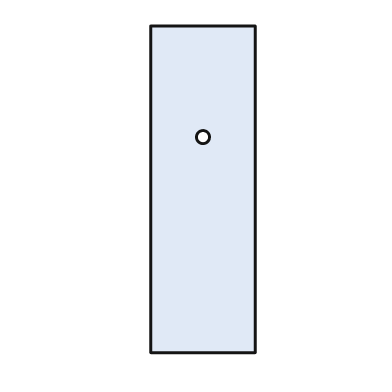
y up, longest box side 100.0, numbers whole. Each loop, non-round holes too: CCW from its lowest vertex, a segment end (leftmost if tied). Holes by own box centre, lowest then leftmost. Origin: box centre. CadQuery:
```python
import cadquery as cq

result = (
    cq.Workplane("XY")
    .moveTo(-16.0, -50.0)
    .lineTo(16.0, -50.0)
    .lineTo(16.0, 50.0)
    .lineTo(-16.0, 50.0)
    .close()
    .moveTo(0.0, 16.0)
    .circle(2.0)
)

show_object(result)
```